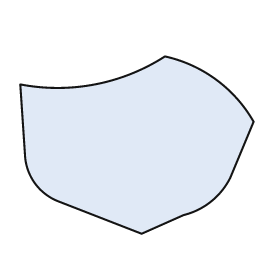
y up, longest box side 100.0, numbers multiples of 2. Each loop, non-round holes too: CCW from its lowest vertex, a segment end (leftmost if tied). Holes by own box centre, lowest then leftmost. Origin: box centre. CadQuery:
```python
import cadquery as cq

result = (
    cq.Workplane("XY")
    .moveTo(2.0, -38.0)
    .lineTo(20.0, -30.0)
    .threePointArc((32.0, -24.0), (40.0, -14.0))
    .lineTo(50.0, 10.0)
    .threePointArc((34.0, 28.0), (12.0, 38.0))
    .threePointArc((-18.0, 26.0), (-50.0, 26.0))
    .lineTo(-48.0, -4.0)
    .threePointArc((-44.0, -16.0), (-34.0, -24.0))
    .close()
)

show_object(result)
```